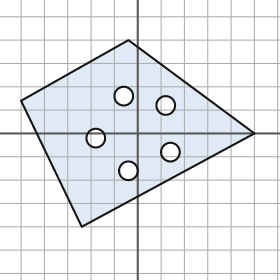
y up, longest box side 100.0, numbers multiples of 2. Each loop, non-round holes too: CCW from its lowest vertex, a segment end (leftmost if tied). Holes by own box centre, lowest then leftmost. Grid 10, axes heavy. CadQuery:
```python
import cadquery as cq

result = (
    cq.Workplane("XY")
    .moveTo(-24.0, -40.0)
    .lineTo(50.0, 0.0)
    .lineTo(-4.0, 40.0)
    .lineTo(-50.0, 14.0)
    .close()
    .moveTo(-4.0, -16.0)
    .circle(4.0)
    .moveTo(14.0, -8.0)
    .circle(4.0)
    .moveTo(-18.0, -2.0)
    .circle(4.0)
    .moveTo(12.0, 12.0)
    .circle(4.0)
    .moveTo(-6.0, 16.0)
    .circle(4.0)
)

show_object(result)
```